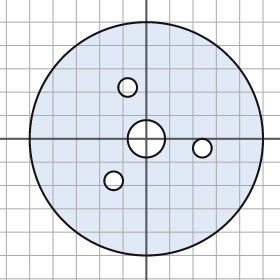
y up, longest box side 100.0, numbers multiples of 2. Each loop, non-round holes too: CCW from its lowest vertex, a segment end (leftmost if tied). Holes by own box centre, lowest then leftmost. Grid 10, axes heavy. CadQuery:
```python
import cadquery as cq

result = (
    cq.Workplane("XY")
    .moveTo(0.0, 0.0)
    .circle(50.0)
    .moveTo(-14.0, -18.0)
    .circle(4.0)
    .moveTo(24.0, -4.0)
    .circle(4.0)
    .moveTo(0.0, 0.0)
    .circle(8.0)
    .moveTo(-8.0, 22.0)
    .circle(4.0)
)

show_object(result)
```